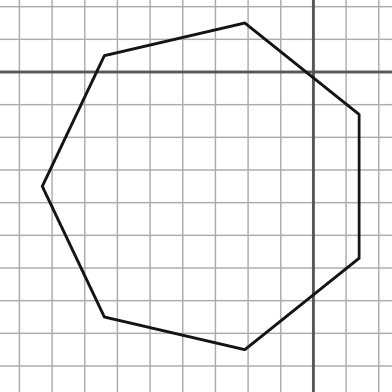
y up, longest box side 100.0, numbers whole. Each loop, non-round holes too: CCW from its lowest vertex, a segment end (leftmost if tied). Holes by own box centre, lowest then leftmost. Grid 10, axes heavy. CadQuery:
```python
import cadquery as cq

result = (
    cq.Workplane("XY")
    .moveTo(-21.0, -85.0)
    .lineTo(14.0, -57.0)
    .lineTo(14.0, -13.0)
    .lineTo(-21.0, 15.0)
    .lineTo(-64.0, 5.0)
    .lineTo(-83.0, -35.0)
    .lineTo(-64.0, -75.0)
    .close()
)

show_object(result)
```